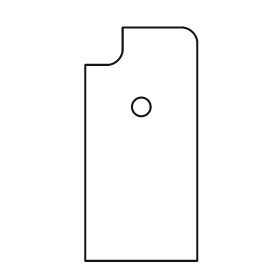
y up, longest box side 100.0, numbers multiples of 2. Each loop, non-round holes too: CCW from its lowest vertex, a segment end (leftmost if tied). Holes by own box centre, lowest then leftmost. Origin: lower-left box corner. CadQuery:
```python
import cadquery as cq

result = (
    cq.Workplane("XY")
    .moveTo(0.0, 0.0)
    .lineTo(48.0, 0.0)
    .lineTo(48.0, 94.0)
    .threePointArc((46.0, 98.0), (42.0, 100.0))
    .lineTo(16.0, 100.0)
    .lineTo(16.0, 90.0)
    .threePointArc((14.0, 86.0), (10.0, 84.0))
    .lineTo(0.0, 84.0)
    .close()
    .moveTo(24.0, 66.0)
    .circle(4.0)
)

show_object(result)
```